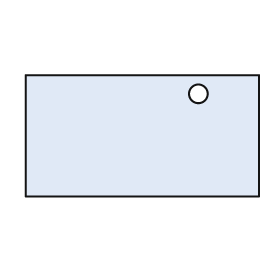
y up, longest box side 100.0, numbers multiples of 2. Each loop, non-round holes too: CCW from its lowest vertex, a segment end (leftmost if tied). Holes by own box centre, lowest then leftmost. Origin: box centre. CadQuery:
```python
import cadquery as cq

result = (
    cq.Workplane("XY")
    .moveTo(-50.0, -26.0)
    .lineTo(50.0, -26.0)
    .lineTo(50.0, 26.0)
    .lineTo(-50.0, 26.0)
    .close()
    .moveTo(24.0, 18.0)
    .circle(4.0)
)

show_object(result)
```